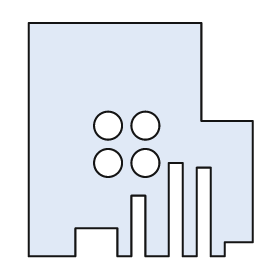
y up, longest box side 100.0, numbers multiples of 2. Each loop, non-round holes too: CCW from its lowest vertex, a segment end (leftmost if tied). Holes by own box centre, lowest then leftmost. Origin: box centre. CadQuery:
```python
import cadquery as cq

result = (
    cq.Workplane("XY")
    .moveTo(-48.0, -50.0)
    .lineTo(-28.0, -50.0)
    .lineTo(-28.0, -38.0)
    .lineTo(-10.0, -38.0)
    .lineTo(-10.0, -50.0)
    .lineTo(-4.0, -50.0)
    .lineTo(-4.0, -24.0)
    .lineTo(2.0, -24.0)
    .lineTo(2.0, -50.0)
    .lineTo(12.0, -50.0)
    .lineTo(12.0, -10.0)
    .lineTo(18.0, -10.0)
    .lineTo(18.0, -50.0)
    .lineTo(24.0, -50.0)
    .lineTo(24.0, -12.0)
    .lineTo(30.0, -12.0)
    .lineTo(30.0, -50.0)
    .lineTo(36.0, -50.0)
    .lineTo(36.0, -44.0)
    .lineTo(48.0, -44.0)
    .lineTo(48.0, 8.0)
    .lineTo(26.0, 8.0)
    .lineTo(26.0, 50.0)
    .lineTo(-48.0, 50.0)
    .close()
    .moveTo(-14.0, -10.0)
    .circle(6.0)
    .moveTo(2.0, -10.0)
    .circle(6.0)
    .moveTo(-14.0, 6.0)
    .circle(6.0)
    .moveTo(2.0, 6.0)
    .circle(6.0)
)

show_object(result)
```